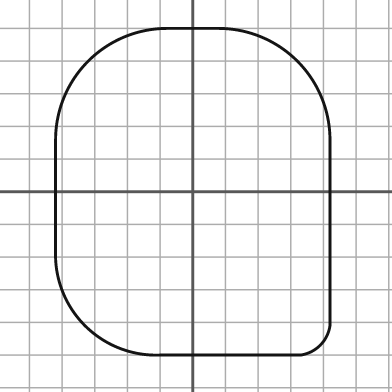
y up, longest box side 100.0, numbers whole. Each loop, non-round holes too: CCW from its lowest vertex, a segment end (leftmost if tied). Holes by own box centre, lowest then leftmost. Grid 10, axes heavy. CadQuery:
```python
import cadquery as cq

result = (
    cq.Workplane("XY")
    .moveTo(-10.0, -50.0)
    .lineTo(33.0, -50.0)
    .threePointArc((39.0, -47.0), (42.0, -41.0))
    .lineTo(42.0, 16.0)
    .threePointArc((32.0, 40.0), (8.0, 50.0))
    .lineTo(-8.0, 50.0)
    .threePointArc((-32.0, 40.0), (-42.0, 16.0))
    .lineTo(-42.0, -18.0)
    .threePointArc((-33.0, -41.0), (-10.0, -50.0))
    .close()
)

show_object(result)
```